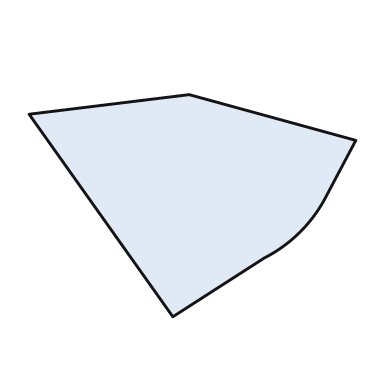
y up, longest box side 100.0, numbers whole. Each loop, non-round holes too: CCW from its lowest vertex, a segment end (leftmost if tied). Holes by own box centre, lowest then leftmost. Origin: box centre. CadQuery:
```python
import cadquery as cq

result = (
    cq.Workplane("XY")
    .moveTo(-6.0, -34.0)
    .lineTo(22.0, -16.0)
    .threePointArc((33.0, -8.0), (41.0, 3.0))
    .lineTo(50.0, 20.0)
    .lineTo(-1.0, 34.0)
    .lineTo(-50.0, 28.0)
    .close()
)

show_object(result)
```